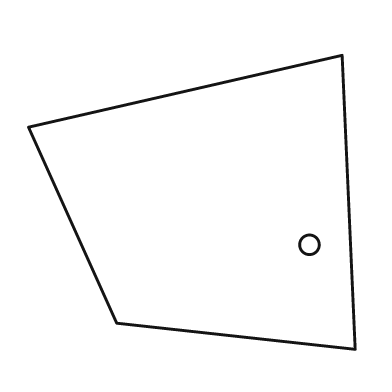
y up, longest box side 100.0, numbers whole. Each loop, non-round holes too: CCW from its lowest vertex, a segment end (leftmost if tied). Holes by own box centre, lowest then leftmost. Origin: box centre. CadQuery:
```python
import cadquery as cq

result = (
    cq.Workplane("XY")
    .moveTo(50.0, -45.0)
    .lineTo(46.0, 45.0)
    .lineTo(-50.0, 23.0)
    .lineTo(-23.0, -37.0)
    .close()
    .moveTo(36.0, -13.0)
    .circle(3.0)
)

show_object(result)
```